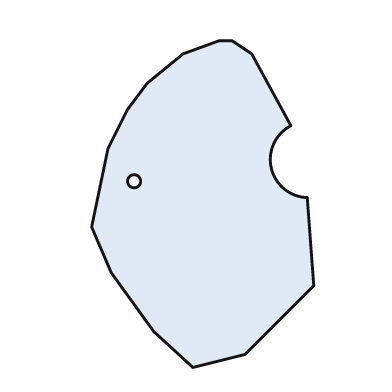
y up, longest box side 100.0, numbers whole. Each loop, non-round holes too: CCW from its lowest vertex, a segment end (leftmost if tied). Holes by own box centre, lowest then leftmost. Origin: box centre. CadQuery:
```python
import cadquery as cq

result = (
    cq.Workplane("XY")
    .moveTo(-3.0, -50.0)
    .lineTo(13.0, -46.0)
    .lineTo(34.0, -25.0)
    .lineTo(32.0, 2.0)
    .threePointArc((21.0, 11.0), (27.0, 24.0))
    .lineTo(15.0, 46.0)
    .lineTo(9.0, 50.0)
    .lineTo(5.0, 50.0)
    .lineTo(-6.0, 46.0)
    .lineTo(-17.0, 37.0)
    .lineTo(-23.0, 29.0)
    .lineTo(-29.0, 17.0)
    .lineTo(-34.0, -7.0)
    .lineTo(-28.0, -21.0)
    .lineTo(-15.0, -39.0)
    .close()
    .moveTo(-21.0, 7.0)
    .circle(2.0)
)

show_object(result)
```